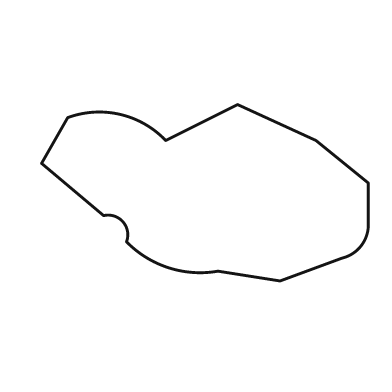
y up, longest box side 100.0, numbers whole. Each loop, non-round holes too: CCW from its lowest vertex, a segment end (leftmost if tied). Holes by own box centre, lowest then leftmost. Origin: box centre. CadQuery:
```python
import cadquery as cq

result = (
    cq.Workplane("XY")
    .moveTo(23.0, -27.0)
    .lineTo(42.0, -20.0)
    .threePointArc((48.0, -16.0), (50.0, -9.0))
    .lineTo(50.0, 3.0)
    .lineTo(34.0, 16.0)
    .lineTo(10.0, 27.0)
    .lineTo(-12.0, 16.0)
    .threePointArc((-26.0, 24.0), (-42.0, 23.0))
    .lineTo(-50.0, 9.0)
    .lineTo(-31.0, -7.0)
    .threePointArc((-25.0, -9.0), (-24.0, -15.0))
    .threePointArc((-11.0, -23.0), (4.0, -24.0))
    .close()
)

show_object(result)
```